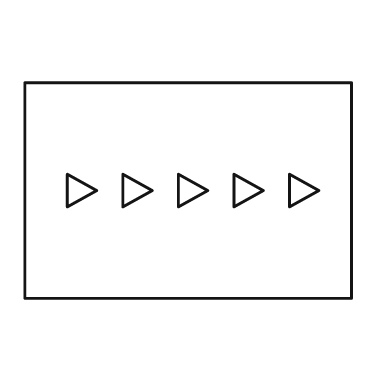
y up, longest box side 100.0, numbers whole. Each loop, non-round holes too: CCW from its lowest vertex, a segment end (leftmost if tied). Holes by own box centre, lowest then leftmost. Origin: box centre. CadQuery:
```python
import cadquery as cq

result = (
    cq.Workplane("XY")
    .moveTo(-50.0, -33.0)
    .lineTo(50.0, -33.0)
    .lineTo(50.0, 33.0)
    .lineTo(-50.0, 33.0)
    .close()
    .moveTo(-37.0, -5.0)
    .lineTo(-28.0, 0.0)
    .lineTo(-37.0, 5.0)
    .close()
    .moveTo(-20.0, -5.0)
    .lineTo(-11.0, 0.0)
    .lineTo(-20.0, 5.0)
    .close()
    .moveTo(-3.0, -5.0)
    .lineTo(6.0, 0.0)
    .lineTo(-3.0, 5.0)
    .close()
    .moveTo(14.0, -5.0)
    .lineTo(23.0, 0.0)
    .lineTo(14.0, 5.0)
    .close()
    .moveTo(31.0, -5.0)
    .lineTo(40.0, 0.0)
    .lineTo(31.0, 5.0)
    .close()
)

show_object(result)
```